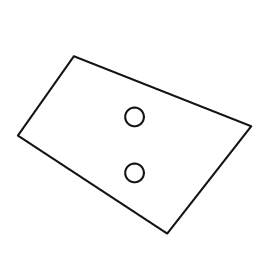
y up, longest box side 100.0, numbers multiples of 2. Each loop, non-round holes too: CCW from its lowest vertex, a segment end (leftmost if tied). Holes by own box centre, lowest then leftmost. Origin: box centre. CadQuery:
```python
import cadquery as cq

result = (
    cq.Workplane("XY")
    .moveTo(14.0, -38.0)
    .lineTo(50.0, 8.0)
    .lineTo(-26.0, 38.0)
    .lineTo(-50.0, 4.0)
    .close()
    .moveTo(0.0, -12.0)
    .circle(4.0)
    .moveTo(0.0, 12.0)
    .circle(4.0)
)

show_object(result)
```